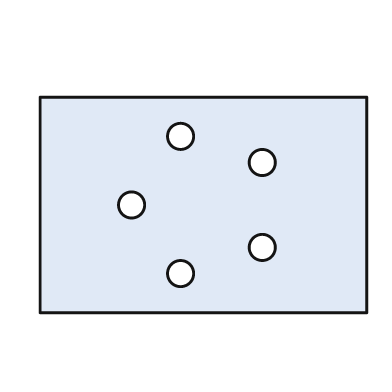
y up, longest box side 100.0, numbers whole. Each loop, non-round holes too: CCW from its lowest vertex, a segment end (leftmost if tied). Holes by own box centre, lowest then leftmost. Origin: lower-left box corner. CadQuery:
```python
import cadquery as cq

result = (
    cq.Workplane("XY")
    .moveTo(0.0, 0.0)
    .lineTo(100.0, 0.0)
    .lineTo(100.0, 66.0)
    .lineTo(0.0, 66.0)
    .close()
    .moveTo(43.0, 12.0)
    .circle(4.0)
    .moveTo(68.0, 20.0)
    .circle(4.0)
    .moveTo(28.0, 33.0)
    .circle(4.0)
    .moveTo(68.0, 46.0)
    .circle(4.0)
    .moveTo(43.0, 54.0)
    .circle(4.0)
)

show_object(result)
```